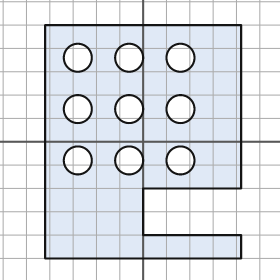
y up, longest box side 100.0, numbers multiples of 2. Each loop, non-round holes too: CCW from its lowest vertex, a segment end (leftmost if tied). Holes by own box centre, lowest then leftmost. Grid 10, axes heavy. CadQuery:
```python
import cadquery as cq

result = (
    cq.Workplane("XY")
    .moveTo(-42.0, -50.0)
    .lineTo(42.0, -50.0)
    .lineTo(42.0, -40.0)
    .lineTo(0.0, -40.0)
    .lineTo(0.0, -20.0)
    .lineTo(42.0, -20.0)
    .lineTo(42.0, 50.0)
    .lineTo(-42.0, 50.0)
    .close()
    .moveTo(-28.0, -8.0)
    .circle(6.0)
    .moveTo(-6.0, -8.0)
    .circle(6.0)
    .moveTo(16.0, -8.0)
    .circle(6.0)
    .moveTo(-28.0, 14.0)
    .circle(6.0)
    .moveTo(-6.0, 14.0)
    .circle(6.0)
    .moveTo(16.0, 14.0)
    .circle(6.0)
    .moveTo(-28.0, 36.0)
    .circle(6.0)
    .moveTo(-6.0, 36.0)
    .circle(6.0)
    .moveTo(16.0, 36.0)
    .circle(6.0)
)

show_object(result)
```